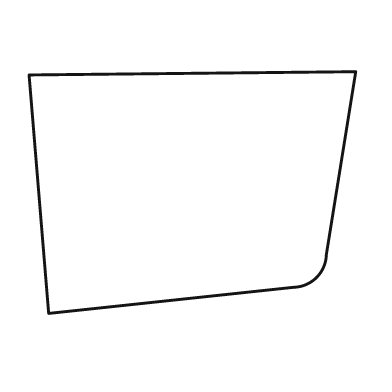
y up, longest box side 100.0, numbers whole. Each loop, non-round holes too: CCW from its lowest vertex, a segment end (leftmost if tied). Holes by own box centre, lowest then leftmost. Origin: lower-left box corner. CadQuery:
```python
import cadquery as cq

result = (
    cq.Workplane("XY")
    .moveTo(6.0, 0.0)
    .lineTo(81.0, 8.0)
    .threePointArc((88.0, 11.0), (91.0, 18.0))
    .lineTo(100.0, 74.0)
    .lineTo(0.0, 73.0)
    .close()
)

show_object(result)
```